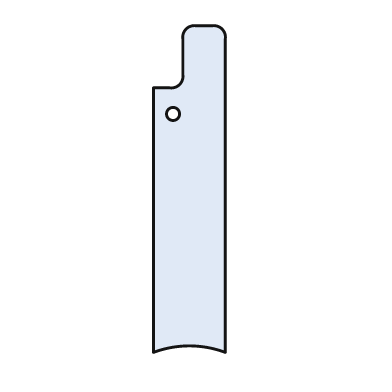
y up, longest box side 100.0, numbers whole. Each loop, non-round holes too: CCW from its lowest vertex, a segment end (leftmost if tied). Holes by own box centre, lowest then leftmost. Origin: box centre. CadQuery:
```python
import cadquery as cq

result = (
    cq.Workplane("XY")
    .moveTo(-11.0, -50.0)
    .threePointArc((0.0, -48.0), (11.0, -50.0))
    .lineTo(11.0, 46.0)
    .threePointArc((10.0, 49.0), (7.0, 50.0))
    .lineTo(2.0, 50.0)
    .threePointArc((-1.0, 49.0), (-2.0, 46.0))
    .lineTo(-2.0, 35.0)
    .threePointArc((-3.0, 32.0), (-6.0, 31.0))
    .lineTo(-11.0, 31.0)
    .close()
    .moveTo(-5.0, 23.0)
    .circle(2.0)
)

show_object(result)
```